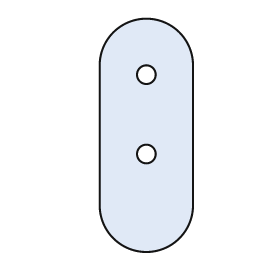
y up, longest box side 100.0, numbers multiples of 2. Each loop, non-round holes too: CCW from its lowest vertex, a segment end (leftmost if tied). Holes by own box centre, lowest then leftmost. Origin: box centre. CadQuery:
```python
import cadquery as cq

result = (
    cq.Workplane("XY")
    .moveTo(-20.0, -30.0)
    .threePointArc((0.0, -50.0), (20.0, -30.0))
    .lineTo(20.0, 30.0)
    .threePointArc((0.0, 50.0), (-20.0, 30.0))
    .close()
    .moveTo(0.0, -8.0)
    .circle(4.0)
    .moveTo(0.0, 26.0)
    .circle(4.0)
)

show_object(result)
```